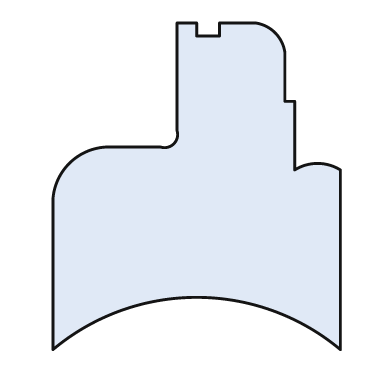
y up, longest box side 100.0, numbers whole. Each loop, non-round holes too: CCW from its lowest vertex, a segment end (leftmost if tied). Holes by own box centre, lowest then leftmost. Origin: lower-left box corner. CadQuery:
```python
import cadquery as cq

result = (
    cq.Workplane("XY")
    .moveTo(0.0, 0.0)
    .threePointArc((44.0, 16.0), (88.0, 0.0))
    .lineTo(88.0, 55.0)
    .threePointArc((81.0, 57.0), (74.0, 55.0))
    .lineTo(74.0, 76.0)
    .lineTo(71.0, 76.0)
    .lineTo(71.0, 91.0)
    .threePointArc((68.0, 97.0), (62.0, 100.0))
    .lineTo(51.0, 100.0)
    .lineTo(51.0, 96.0)
    .lineTo(44.0, 96.0)
    .lineTo(44.0, 100.0)
    .lineTo(38.0, 100.0)
    .lineTo(38.0, 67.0)
    .threePointArc((37.0, 63.0), (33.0, 62.0))
    .lineTo(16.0, 62.0)
    .threePointArc((5.0, 57.0), (0.0, 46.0))
    .close()
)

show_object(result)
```